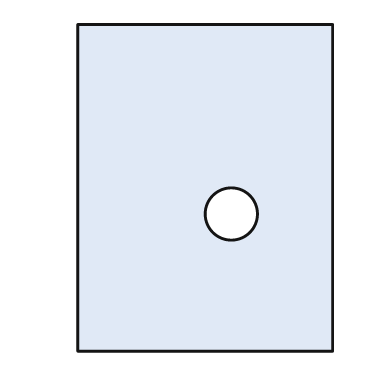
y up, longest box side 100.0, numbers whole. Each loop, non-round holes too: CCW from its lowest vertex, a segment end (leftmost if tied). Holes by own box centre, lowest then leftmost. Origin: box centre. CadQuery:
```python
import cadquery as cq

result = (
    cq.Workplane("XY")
    .moveTo(-39.0, -50.0)
    .lineTo(39.0, -50.0)
    .lineTo(39.0, 50.0)
    .lineTo(-39.0, 50.0)
    .close()
    .moveTo(8.0, -8.0)
    .circle(8.0)
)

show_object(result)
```